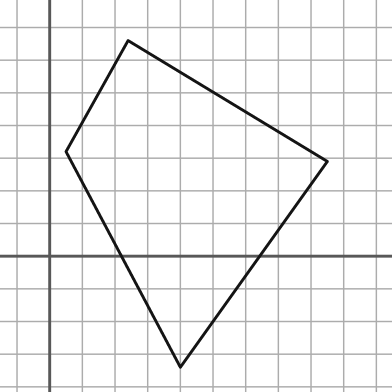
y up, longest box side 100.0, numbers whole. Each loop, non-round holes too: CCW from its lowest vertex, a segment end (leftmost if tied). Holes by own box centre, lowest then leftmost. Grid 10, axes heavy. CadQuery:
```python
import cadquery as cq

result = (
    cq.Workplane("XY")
    .moveTo(40.0, -34.0)
    .lineTo(85.0, 29.0)
    .lineTo(24.0, 66.0)
    .lineTo(5.0, 32.0)
    .close()
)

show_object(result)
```